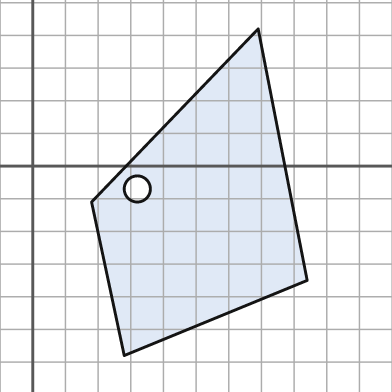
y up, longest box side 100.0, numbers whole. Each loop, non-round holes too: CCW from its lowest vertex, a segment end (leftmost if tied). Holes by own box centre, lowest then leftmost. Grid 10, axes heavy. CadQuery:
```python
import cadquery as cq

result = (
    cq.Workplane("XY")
    .moveTo(28.0, -58.0)
    .lineTo(84.0, -35.0)
    .lineTo(69.0, 42.0)
    .lineTo(18.0, -11.0)
    .close()
    .moveTo(32.0, -7.0)
    .circle(4.0)
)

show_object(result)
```